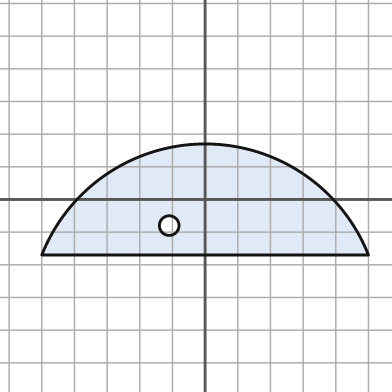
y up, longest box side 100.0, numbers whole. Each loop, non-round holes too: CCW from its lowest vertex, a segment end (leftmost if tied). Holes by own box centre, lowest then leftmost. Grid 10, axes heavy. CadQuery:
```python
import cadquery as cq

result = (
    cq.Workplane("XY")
    .moveTo(-50.0, -17.0)
    .lineTo(50.0, -17.0)
    .threePointArc((0.0, 17.0), (-50.0, -17.0))
    .close()
    .moveTo(-11.0, -8.0)
    .circle(3.0)
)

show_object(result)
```